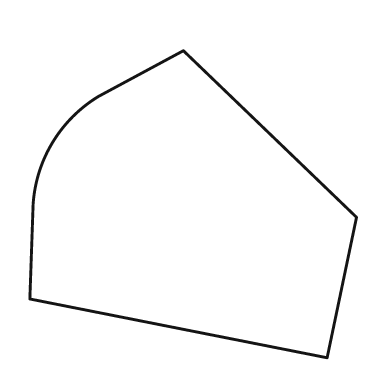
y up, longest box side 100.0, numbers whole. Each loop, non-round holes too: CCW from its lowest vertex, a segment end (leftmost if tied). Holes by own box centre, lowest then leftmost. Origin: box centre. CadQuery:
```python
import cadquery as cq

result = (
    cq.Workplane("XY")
    .moveTo(41.0, -47.0)
    .lineTo(50.0, -4.0)
    .lineTo(-3.0, 47.0)
    .lineTo(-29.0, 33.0)
    .threePointArc((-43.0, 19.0), (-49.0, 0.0))
    .lineTo(-50.0, -29.0)
    .close()
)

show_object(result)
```